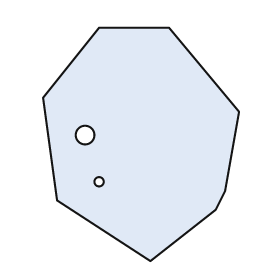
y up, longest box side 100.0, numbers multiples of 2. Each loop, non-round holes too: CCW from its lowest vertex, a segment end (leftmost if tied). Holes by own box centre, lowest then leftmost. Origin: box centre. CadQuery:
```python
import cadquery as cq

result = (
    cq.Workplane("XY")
    .moveTo(4.0, -50.0)
    .lineTo(32.0, -28.0)
    .lineTo(36.0, -20.0)
    .lineTo(42.0, 14.0)
    .lineTo(12.0, 50.0)
    .lineTo(-18.0, 50.0)
    .lineTo(-42.0, 20.0)
    .lineTo(-36.0, -24.0)
    .close()
    .moveTo(-18.0, -16.0)
    .circle(2.0)
    .moveTo(-24.0, 4.0)
    .circle(4.0)
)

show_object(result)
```